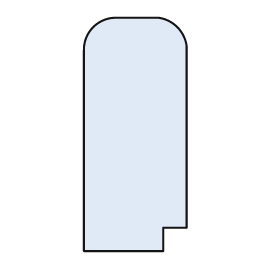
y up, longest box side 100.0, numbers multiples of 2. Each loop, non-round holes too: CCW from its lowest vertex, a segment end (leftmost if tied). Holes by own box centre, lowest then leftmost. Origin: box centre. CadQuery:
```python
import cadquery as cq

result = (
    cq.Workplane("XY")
    .moveTo(-22.0, -50.0)
    .lineTo(12.0, -50.0)
    .lineTo(12.0, -40.0)
    .lineTo(22.0, -40.0)
    .lineTo(22.0, 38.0)
    .threePointArc((18.0, 46.0), (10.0, 50.0))
    .lineTo(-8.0, 50.0)
    .threePointArc((-18.0, 46.0), (-22.0, 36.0))
    .close()
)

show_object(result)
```